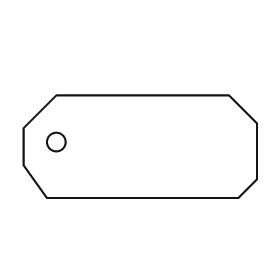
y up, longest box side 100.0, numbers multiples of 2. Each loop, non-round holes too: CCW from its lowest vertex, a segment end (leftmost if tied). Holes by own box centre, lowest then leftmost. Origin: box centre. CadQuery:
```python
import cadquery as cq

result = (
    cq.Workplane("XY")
    .moveTo(-40.0, -22.0)
    .lineTo(42.0, -22.0)
    .lineTo(50.0, -14.0)
    .lineTo(50.0, 10.0)
    .lineTo(38.0, 22.0)
    .lineTo(-36.0, 22.0)
    .lineTo(-50.0, 8.0)
    .lineTo(-50.0, -8.0)
    .close()
    .moveTo(-36.0, 2.0)
    .circle(4.0)
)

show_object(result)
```